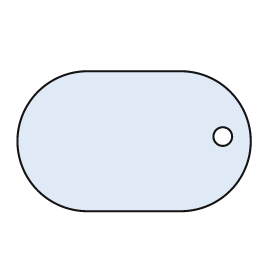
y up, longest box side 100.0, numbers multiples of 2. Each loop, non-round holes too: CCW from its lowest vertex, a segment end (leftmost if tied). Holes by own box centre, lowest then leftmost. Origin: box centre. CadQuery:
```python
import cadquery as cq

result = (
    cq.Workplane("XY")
    .moveTo(-20.0, -30.0)
    .lineTo(20.0, -30.0)
    .threePointArc((50.0, 0.0), (20.0, 30.0))
    .lineTo(-20.0, 30.0)
    .threePointArc((-50.0, 0.0), (-20.0, -30.0))
    .close()
    .moveTo(38.0, 2.0)
    .circle(4.0)
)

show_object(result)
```